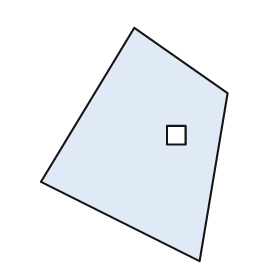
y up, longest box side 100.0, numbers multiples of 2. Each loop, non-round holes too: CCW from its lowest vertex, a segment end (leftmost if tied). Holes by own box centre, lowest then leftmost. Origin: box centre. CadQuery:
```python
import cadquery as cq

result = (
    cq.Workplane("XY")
    .moveTo(28.0, -50.0)
    .lineTo(40.0, 22.0)
    .lineTo(0.0, 50.0)
    .lineTo(-40.0, -16.0)
    .close()
    .moveTo(14.0, 0.0)
    .lineTo(22.0, 0.0)
    .lineTo(22.0, 8.0)
    .lineTo(14.0, 8.0)
    .close()
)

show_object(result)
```